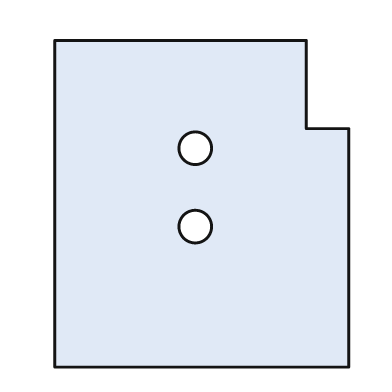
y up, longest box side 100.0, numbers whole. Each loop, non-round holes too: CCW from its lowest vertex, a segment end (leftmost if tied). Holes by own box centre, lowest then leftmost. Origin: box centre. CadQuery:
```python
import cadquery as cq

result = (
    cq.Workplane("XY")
    .moveTo(-45.0, -50.0)
    .lineTo(45.0, -50.0)
    .lineTo(45.0, 23.0)
    .lineTo(32.0, 23.0)
    .lineTo(32.0, 50.0)
    .lineTo(-45.0, 50.0)
    .close()
    .moveTo(-2.0, -7.0)
    .circle(5.0)
    .moveTo(-2.0, 17.0)
    .circle(5.0)
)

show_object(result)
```